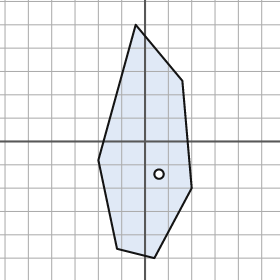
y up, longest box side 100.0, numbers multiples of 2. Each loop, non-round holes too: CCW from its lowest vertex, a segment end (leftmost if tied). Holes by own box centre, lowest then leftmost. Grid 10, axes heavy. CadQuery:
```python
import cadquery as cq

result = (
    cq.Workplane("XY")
    .moveTo(4.0, -50.0)
    .lineTo(20.0, -20.0)
    .lineTo(16.0, 26.0)
    .lineTo(-4.0, 50.0)
    .lineTo(-20.0, -8.0)
    .lineTo(-12.0, -46.0)
    .close()
    .moveTo(6.0, -14.0)
    .circle(2.0)
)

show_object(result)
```